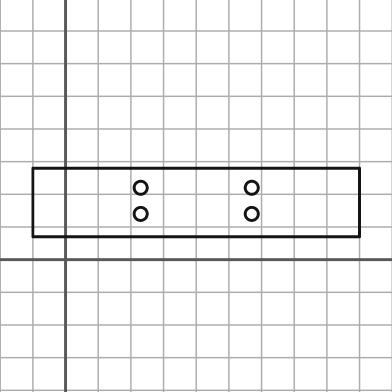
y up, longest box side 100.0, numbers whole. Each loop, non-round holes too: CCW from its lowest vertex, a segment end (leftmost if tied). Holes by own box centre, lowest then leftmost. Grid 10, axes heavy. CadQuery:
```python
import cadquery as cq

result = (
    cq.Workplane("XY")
    .moveTo(-10.0, 7.0)
    .lineTo(90.0, 7.0)
    .lineTo(90.0, 28.0)
    .lineTo(-10.0, 28.0)
    .close()
    .moveTo(23.0, 14.0)
    .circle(2.0)
    .moveTo(57.0, 14.0)
    .circle(2.0)
    .moveTo(23.0, 22.0)
    .circle(2.0)
    .moveTo(57.0, 22.0)
    .circle(2.0)
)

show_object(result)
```